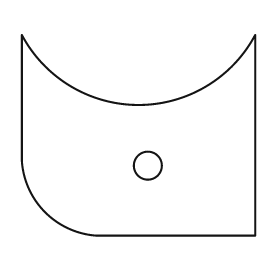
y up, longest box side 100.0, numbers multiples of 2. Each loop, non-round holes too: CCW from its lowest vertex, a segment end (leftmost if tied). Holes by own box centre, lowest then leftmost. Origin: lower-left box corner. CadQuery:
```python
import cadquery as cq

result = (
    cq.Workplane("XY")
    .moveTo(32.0, 0.0)
    .lineTo(100.0, 0.0)
    .lineTo(100.0, 86.0)
    .threePointArc((50.0, 56.0), (0.0, 86.0))
    .lineTo(0.0, 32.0)
    .threePointArc((10.0, 10.0), (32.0, 0.0))
    .close()
    .moveTo(54.0, 30.0)
    .circle(6.0)
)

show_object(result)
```